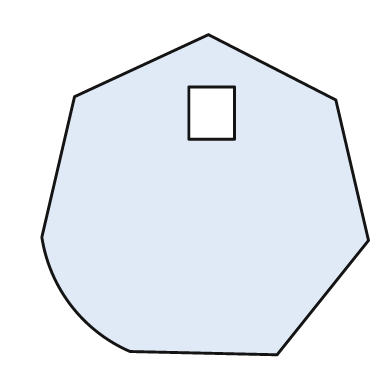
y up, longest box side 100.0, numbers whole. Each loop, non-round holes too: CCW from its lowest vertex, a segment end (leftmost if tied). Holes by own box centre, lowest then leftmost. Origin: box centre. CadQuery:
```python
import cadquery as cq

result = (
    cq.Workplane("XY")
    .moveTo(22.0, -49.0)
    .lineTo(50.0, -14.0)
    .lineTo(40.0, 29.0)
    .lineTo(1.0, 49.0)
    .lineTo(-40.0, 30.0)
    .lineTo(-50.0, -13.0)
    .threePointArc((-41.0, -34.0), (-23.0, -48.0))
    .close()
    .moveTo(-5.0, 17.0)
    .lineTo(9.0, 17.0)
    .lineTo(9.0, 33.0)
    .lineTo(-5.0, 33.0)
    .close()
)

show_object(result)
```